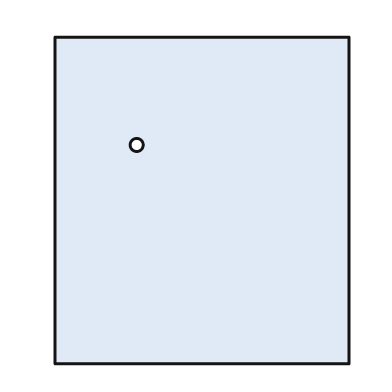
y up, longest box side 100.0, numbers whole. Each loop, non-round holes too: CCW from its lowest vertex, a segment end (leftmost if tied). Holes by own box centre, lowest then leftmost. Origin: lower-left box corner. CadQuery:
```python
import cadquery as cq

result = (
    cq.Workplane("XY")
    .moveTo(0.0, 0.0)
    .lineTo(90.0, 0.0)
    .lineTo(90.0, 100.0)
    .lineTo(0.0, 100.0)
    .close()
    .moveTo(25.0, 67.0)
    .circle(2.0)
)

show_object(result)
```